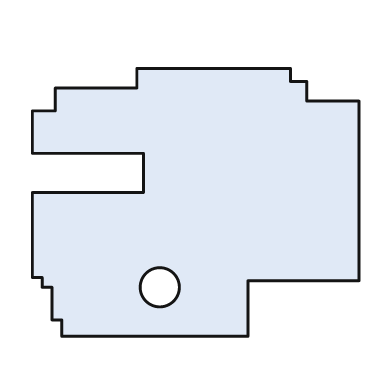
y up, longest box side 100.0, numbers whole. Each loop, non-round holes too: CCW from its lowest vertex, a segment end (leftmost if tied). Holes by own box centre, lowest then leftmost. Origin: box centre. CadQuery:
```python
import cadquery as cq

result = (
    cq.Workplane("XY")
    .moveTo(-41.0, -41.0)
    .lineTo(16.0, -41.0)
    .lineTo(16.0, -24.0)
    .lineTo(50.0, -24.0)
    .lineTo(50.0, 31.0)
    .lineTo(34.0, 31.0)
    .lineTo(34.0, 37.0)
    .lineTo(29.0, 37.0)
    .lineTo(29.0, 41.0)
    .lineTo(-18.0, 41.0)
    .lineTo(-18.0, 35.0)
    .lineTo(-43.0, 35.0)
    .lineTo(-43.0, 28.0)
    .lineTo(-50.0, 28.0)
    .lineTo(-50.0, 15.0)
    .lineTo(-16.0, 15.0)
    .lineTo(-16.0, 3.0)
    .lineTo(-50.0, 3.0)
    .lineTo(-50.0, -23.0)
    .lineTo(-47.0, -23.0)
    .lineTo(-47.0, -26.0)
    .lineTo(-44.0, -26.0)
    .lineTo(-44.0, -36.0)
    .lineTo(-41.0, -36.0)
    .close()
    .moveTo(-11.0, -26.0)
    .circle(6.0)
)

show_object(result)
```